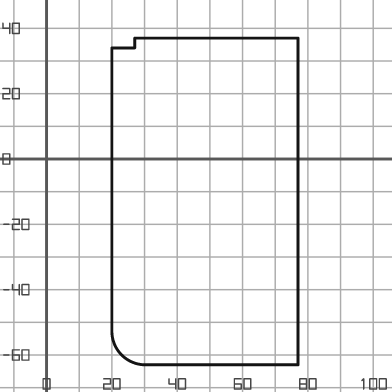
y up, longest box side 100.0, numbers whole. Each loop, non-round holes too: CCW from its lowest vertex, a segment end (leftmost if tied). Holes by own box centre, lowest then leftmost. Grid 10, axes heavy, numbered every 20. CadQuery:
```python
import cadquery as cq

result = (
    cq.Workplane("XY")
    .moveTo(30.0, -63.0)
    .lineTo(77.0, -63.0)
    .lineTo(77.0, 37.0)
    .lineTo(27.0, 37.0)
    .lineTo(27.0, 34.0)
    .lineTo(20.0, 34.0)
    .lineTo(20.0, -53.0)
    .threePointArc((23.0, -60.0), (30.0, -63.0))
    .close()
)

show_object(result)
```